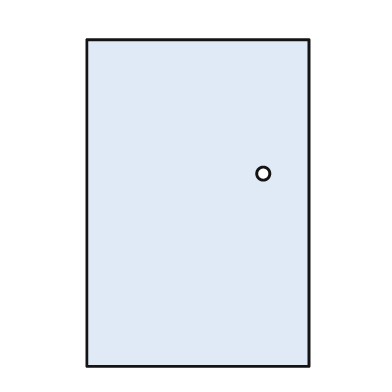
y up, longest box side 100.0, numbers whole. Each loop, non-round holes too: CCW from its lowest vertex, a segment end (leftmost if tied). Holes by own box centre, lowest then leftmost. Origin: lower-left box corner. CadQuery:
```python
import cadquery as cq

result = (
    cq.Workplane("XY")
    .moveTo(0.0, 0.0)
    .lineTo(68.0, 0.0)
    .lineTo(68.0, 100.0)
    .lineTo(0.0, 100.0)
    .close()
    .moveTo(54.0, 59.0)
    .circle(2.0)
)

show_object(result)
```